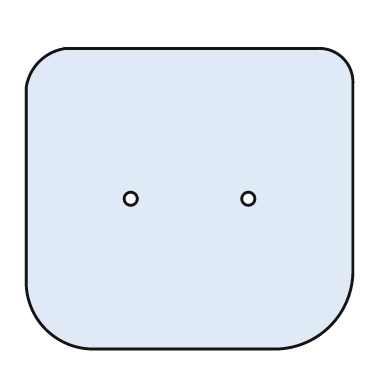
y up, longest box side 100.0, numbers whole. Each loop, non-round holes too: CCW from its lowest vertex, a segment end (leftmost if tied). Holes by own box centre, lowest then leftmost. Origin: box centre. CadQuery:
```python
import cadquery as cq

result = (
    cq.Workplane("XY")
    .moveTo(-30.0, -46.0)
    .lineTo(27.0, -46.0)
    .threePointArc((43.0, -39.0), (50.0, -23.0))
    .lineTo(50.0, 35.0)
    .threePointArc((47.0, 43.0), (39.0, 46.0))
    .lineTo(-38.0, 46.0)
    .threePointArc((-46.0, 42.0), (-50.0, 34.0))
    .lineTo(-50.0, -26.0)
    .threePointArc((-44.0, -40.0), (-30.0, -46.0))
    .close()
    .moveTo(-18.0, 0.0)
    .circle(2.0)
    .moveTo(18.0, 0.0)
    .circle(2.0)
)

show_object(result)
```